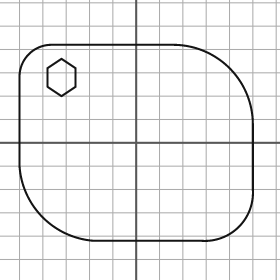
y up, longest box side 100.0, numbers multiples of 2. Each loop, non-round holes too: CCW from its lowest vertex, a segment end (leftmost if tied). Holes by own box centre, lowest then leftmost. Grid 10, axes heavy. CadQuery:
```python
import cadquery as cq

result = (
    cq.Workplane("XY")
    .moveTo(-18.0, -42.0)
    .lineTo(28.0, -42.0)
    .threePointArc((44.0, -36.0), (50.0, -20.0))
    .lineTo(50.0, 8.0)
    .threePointArc((40.0, 32.0), (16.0, 42.0))
    .lineTo(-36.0, 42.0)
    .threePointArc((-46.0, 38.0), (-50.0, 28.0))
    .lineTo(-50.0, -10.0)
    .threePointArc((-40.0, -32.0), (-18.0, -42.0))
    .close()
    .moveTo(-32.0, 20.0)
    .lineTo(-26.0, 24.0)
    .lineTo(-26.0, 32.0)
    .lineTo(-32.0, 36.0)
    .lineTo(-38.0, 32.0)
    .lineTo(-38.0, 24.0)
    .close()
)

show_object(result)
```